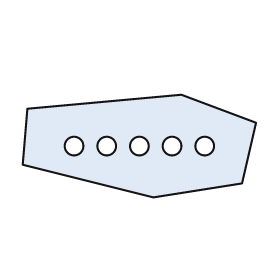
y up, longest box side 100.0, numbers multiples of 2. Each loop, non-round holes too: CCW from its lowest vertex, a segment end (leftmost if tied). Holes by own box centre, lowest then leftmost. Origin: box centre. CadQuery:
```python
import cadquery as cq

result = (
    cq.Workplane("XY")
    .moveTo(6.0, -22.0)
    .lineTo(44.0, -16.0)
    .lineTo(50.0, 10.0)
    .lineTo(18.0, 22.0)
    .lineTo(-48.0, 16.0)
    .lineTo(-50.0, -8.0)
    .close()
    .moveTo(-28.0, 0.0)
    .circle(4.0)
    .moveTo(-14.0, 0.0)
    .circle(4.0)
    .moveTo(0.0, 0.0)
    .circle(4.0)
    .moveTo(14.0, 0.0)
    .circle(4.0)
    .moveTo(28.0, 0.0)
    .circle(4.0)
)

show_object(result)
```